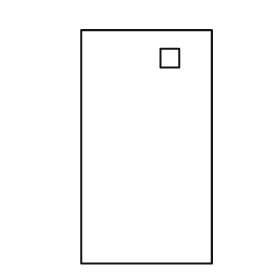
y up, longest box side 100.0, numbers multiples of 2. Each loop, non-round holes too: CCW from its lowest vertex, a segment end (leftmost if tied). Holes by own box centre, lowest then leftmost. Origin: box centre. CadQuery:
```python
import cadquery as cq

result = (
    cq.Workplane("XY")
    .moveTo(-28.0, -50.0)
    .lineTo(28.0, -50.0)
    .lineTo(28.0, 50.0)
    .lineTo(-28.0, 50.0)
    .close()
    .moveTo(6.0, 34.0)
    .lineTo(14.0, 34.0)
    .lineTo(14.0, 42.0)
    .lineTo(6.0, 42.0)
    .close()
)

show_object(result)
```